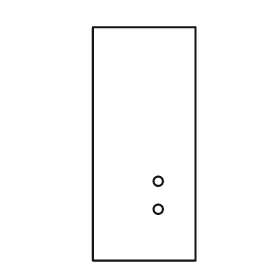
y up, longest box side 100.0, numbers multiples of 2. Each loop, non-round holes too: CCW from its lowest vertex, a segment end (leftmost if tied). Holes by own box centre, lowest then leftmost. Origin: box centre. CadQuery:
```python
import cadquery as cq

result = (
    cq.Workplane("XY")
    .moveTo(-22.0, -50.0)
    .lineTo(22.0, -50.0)
    .lineTo(22.0, 50.0)
    .lineTo(-22.0, 50.0)
    .close()
    .moveTo(6.0, -28.0)
    .circle(2.0)
    .moveTo(6.0, -16.0)
    .circle(2.0)
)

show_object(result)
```